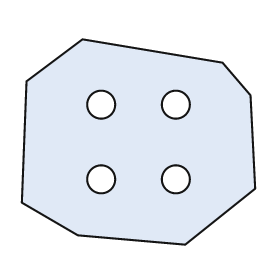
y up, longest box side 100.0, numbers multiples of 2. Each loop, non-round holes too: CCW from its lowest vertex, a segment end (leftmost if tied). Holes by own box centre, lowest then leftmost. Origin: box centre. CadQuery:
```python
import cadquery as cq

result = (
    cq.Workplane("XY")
    .moveTo(20.0, -44.0)
    .lineTo(50.0, -20.0)
    .lineTo(48.0, 20.0)
    .lineTo(36.0, 34.0)
    .lineTo(-24.0, 44.0)
    .lineTo(-48.0, 26.0)
    .lineTo(-50.0, -26.0)
    .lineTo(-26.0, -40.0)
    .close()
    .moveTo(-16.0, -16.0)
    .circle(6.0)
    .moveTo(16.0, -16.0)
    .circle(6.0)
    .moveTo(-16.0, 16.0)
    .circle(6.0)
    .moveTo(16.0, 16.0)
    .circle(6.0)
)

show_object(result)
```